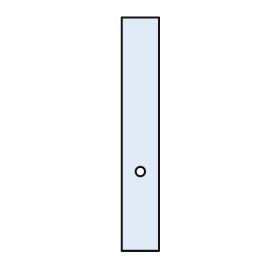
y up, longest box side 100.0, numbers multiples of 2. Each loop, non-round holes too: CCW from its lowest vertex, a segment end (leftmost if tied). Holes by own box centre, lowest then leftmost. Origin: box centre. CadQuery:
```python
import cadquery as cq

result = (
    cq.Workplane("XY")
    .moveTo(-8.0, -50.0)
    .lineTo(8.0, -50.0)
    .lineTo(8.0, 50.0)
    .lineTo(-8.0, 50.0)
    .close()
    .moveTo(0.0, -16.0)
    .circle(2.0)
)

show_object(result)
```